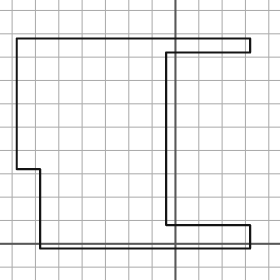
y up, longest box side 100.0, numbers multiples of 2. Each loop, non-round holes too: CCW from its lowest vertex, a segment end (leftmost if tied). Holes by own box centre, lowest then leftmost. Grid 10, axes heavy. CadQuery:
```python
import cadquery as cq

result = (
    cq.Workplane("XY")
    .moveTo(-58.0, -2.0)
    .lineTo(32.0, -2.0)
    .lineTo(32.0, 8.0)
    .lineTo(-4.0, 8.0)
    .lineTo(-4.0, 82.0)
    .lineTo(32.0, 82.0)
    .lineTo(32.0, 88.0)
    .lineTo(-68.0, 88.0)
    .lineTo(-68.0, 32.0)
    .lineTo(-58.0, 32.0)
    .close()
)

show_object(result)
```